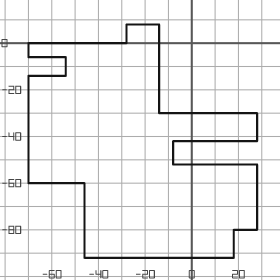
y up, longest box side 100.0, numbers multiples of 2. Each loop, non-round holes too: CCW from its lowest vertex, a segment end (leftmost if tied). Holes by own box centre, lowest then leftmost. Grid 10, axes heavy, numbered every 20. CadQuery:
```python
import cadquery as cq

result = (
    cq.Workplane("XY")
    .moveTo(-46.0, -92.0)
    .lineTo(18.0, -92.0)
    .lineTo(18.0, -80.0)
    .lineTo(28.0, -80.0)
    .lineTo(28.0, -52.0)
    .lineTo(-8.0, -52.0)
    .lineTo(-8.0, -42.0)
    .lineTo(28.0, -42.0)
    .lineTo(28.0, -30.0)
    .lineTo(-14.0, -30.0)
    .lineTo(-14.0, 8.0)
    .lineTo(-28.0, 8.0)
    .lineTo(-28.0, 0.0)
    .lineTo(-70.0, 0.0)
    .lineTo(-70.0, -6.0)
    .lineTo(-54.0, -6.0)
    .lineTo(-54.0, -14.0)
    .lineTo(-70.0, -14.0)
    .lineTo(-70.0, -60.0)
    .lineTo(-46.0, -60.0)
    .close()
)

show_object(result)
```